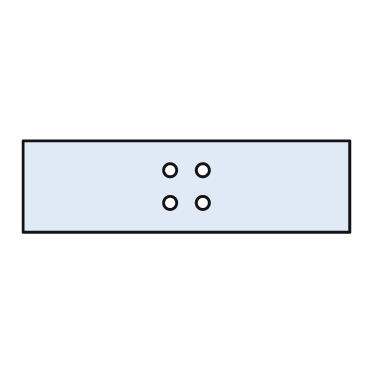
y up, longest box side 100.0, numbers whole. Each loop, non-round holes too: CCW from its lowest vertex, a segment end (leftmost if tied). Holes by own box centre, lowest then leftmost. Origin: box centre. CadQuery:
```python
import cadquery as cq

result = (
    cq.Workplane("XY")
    .moveTo(-50.0, -14.0)
    .lineTo(50.0, -14.0)
    .lineTo(50.0, 14.0)
    .lineTo(-50.0, 14.0)
    .close()
    .moveTo(-5.0, -5.0)
    .circle(2.0)
    .moveTo(5.0, -5.0)
    .circle(2.0)
    .moveTo(-5.0, 5.0)
    .circle(2.0)
    .moveTo(5.0, 5.0)
    .circle(2.0)
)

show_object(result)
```